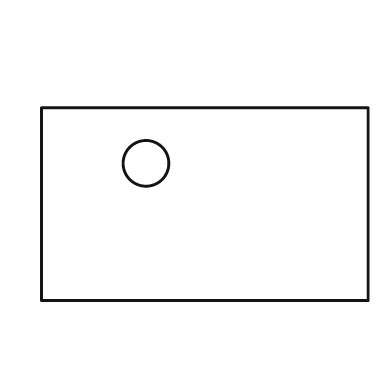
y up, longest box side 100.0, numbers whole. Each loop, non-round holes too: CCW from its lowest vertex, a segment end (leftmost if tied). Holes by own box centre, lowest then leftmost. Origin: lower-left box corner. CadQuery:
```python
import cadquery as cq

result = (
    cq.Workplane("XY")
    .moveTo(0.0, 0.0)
    .lineTo(100.0, 0.0)
    .lineTo(100.0, 59.0)
    .lineTo(0.0, 59.0)
    .close()
    .moveTo(32.0, 42.0)
    .circle(7.0)
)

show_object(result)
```